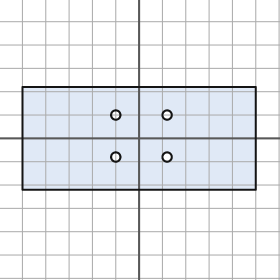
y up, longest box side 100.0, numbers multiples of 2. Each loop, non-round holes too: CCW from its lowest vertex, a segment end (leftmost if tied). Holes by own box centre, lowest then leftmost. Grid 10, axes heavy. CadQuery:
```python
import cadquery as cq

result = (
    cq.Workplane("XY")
    .moveTo(-50.0, -22.0)
    .lineTo(50.0, -22.0)
    .lineTo(50.0, 22.0)
    .lineTo(-50.0, 22.0)
    .close()
    .moveTo(-10.0, -8.0)
    .circle(2.0)
    .moveTo(12.0, -8.0)
    .circle(2.0)
    .moveTo(-10.0, 10.0)
    .circle(2.0)
    .moveTo(12.0, 10.0)
    .circle(2.0)
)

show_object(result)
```